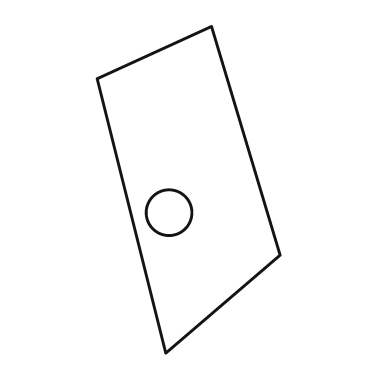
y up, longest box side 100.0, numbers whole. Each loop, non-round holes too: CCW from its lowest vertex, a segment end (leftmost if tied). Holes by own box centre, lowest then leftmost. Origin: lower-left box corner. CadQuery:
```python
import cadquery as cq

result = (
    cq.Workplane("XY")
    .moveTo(21.0, 0.0)
    .lineTo(56.0, 30.0)
    .lineTo(35.0, 100.0)
    .lineTo(0.0, 84.0)
    .close()
    .moveTo(22.0, 43.0)
    .circle(7.0)
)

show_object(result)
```